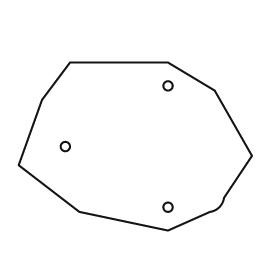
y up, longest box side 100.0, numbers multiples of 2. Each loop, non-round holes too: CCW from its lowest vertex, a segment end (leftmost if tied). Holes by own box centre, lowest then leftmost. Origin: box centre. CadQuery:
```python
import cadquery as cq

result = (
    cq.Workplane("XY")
    .moveTo(14.0, -36.0)
    .lineTo(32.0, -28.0)
    .threePointArc((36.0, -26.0), (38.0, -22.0))
    .lineTo(50.0, -4.0)
    .lineTo(34.0, 24.0)
    .lineTo(14.0, 36.0)
    .lineTo(-28.0, 36.0)
    .lineTo(-40.0, 20.0)
    .lineTo(-50.0, -8.0)
    .lineTo(-24.0, -28.0)
    .close()
    .moveTo(14.0, -26.0)
    .circle(2.0)
    .moveTo(-30.0, 0.0)
    .circle(2.0)
    .moveTo(14.0, 26.0)
    .circle(2.0)
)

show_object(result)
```